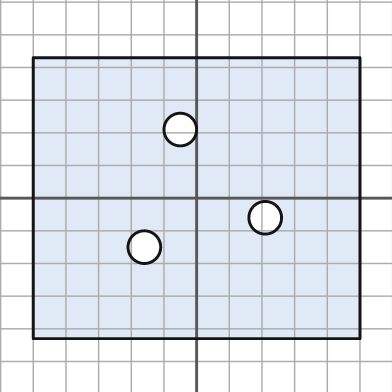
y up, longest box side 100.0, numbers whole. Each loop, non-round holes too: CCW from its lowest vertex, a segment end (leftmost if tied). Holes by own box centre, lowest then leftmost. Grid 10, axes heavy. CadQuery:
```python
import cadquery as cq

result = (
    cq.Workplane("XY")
    .moveTo(-50.0, -43.0)
    .lineTo(50.0, -43.0)
    .lineTo(50.0, 43.0)
    .lineTo(-50.0, 43.0)
    .close()
    .moveTo(-16.0, -15.0)
    .circle(5.0)
    .moveTo(21.0, -6.0)
    .circle(5.0)
    .moveTo(-5.0, 21.0)
    .circle(5.0)
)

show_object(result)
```